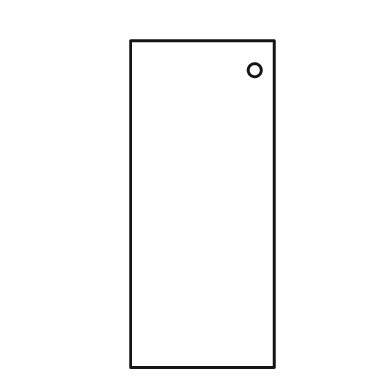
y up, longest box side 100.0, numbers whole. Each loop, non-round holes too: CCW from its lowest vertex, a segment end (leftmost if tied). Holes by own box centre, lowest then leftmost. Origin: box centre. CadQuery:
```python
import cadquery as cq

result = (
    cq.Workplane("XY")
    .moveTo(-22.0, -50.0)
    .lineTo(22.0, -50.0)
    .lineTo(22.0, 50.0)
    .lineTo(-22.0, 50.0)
    .close()
    .moveTo(16.0, 41.0)
    .circle(2.0)
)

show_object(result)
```